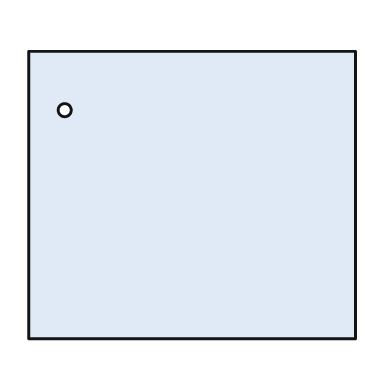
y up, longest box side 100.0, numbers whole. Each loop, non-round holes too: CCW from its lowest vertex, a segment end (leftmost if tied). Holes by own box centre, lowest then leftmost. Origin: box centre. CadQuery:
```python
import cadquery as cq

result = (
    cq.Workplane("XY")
    .moveTo(-50.0, -44.0)
    .lineTo(50.0, -44.0)
    .lineTo(50.0, 44.0)
    .lineTo(-50.0, 44.0)
    .close()
    .moveTo(-39.0, 26.0)
    .circle(2.0)
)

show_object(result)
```